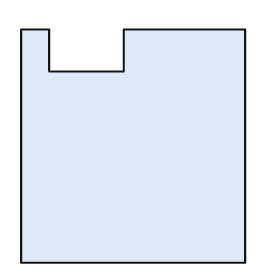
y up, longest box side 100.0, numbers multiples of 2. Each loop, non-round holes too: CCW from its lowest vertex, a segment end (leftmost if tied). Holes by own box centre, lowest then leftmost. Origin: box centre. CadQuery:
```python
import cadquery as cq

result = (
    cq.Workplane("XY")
    .moveTo(-48.0, -50.0)
    .lineTo(48.0, -50.0)
    .lineTo(48.0, 50.0)
    .lineTo(-4.0, 50.0)
    .lineTo(-4.0, 32.0)
    .lineTo(-36.0, 32.0)
    .lineTo(-36.0, 50.0)
    .lineTo(-48.0, 50.0)
    .close()
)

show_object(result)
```